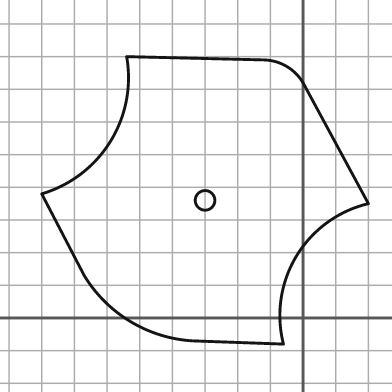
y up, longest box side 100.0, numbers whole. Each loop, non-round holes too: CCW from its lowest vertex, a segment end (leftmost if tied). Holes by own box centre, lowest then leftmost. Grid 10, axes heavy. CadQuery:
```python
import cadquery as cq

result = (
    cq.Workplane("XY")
    .moveTo(-6.0, -8.0)
    .threePointArc((-2.0, 19.0), (20.0, 35.0))
    .lineTo(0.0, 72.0)
    .threePointArc((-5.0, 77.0), (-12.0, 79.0))
    .lineTo(-54.0, 80.0)
    .threePointArc((-59.0, 54.0), (-80.0, 38.0))
    .lineTo(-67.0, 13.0)
    .threePointArc((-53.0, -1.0), (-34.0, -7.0))
    .close()
    .moveTo(-30.0, 36.0)
    .circle(3.0)
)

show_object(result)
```